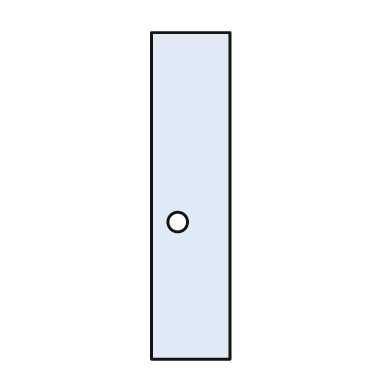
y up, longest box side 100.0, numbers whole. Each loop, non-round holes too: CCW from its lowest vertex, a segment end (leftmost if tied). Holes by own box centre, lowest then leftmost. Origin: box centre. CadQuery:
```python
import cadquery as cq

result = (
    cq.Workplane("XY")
    .moveTo(-12.0, -50.0)
    .lineTo(12.0, -50.0)
    .lineTo(12.0, 50.0)
    .lineTo(-12.0, 50.0)
    .close()
    .moveTo(-4.0, -8.0)
    .circle(3.0)
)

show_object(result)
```